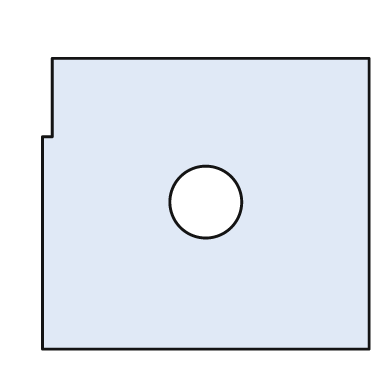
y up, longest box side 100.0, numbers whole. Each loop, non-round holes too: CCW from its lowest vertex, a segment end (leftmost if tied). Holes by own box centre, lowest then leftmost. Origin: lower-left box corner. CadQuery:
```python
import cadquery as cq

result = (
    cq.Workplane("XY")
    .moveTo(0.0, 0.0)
    .lineTo(100.0, 0.0)
    .lineTo(100.0, 89.0)
    .lineTo(3.0, 89.0)
    .lineTo(3.0, 65.0)
    .lineTo(0.0, 65.0)
    .close()
    .moveTo(50.0, 45.0)
    .circle(11.0)
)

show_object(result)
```